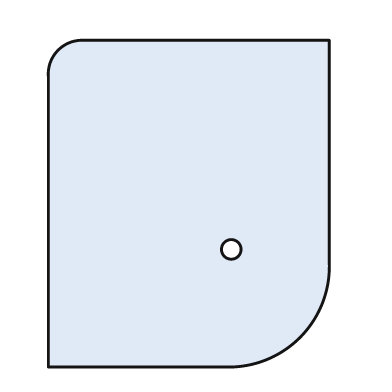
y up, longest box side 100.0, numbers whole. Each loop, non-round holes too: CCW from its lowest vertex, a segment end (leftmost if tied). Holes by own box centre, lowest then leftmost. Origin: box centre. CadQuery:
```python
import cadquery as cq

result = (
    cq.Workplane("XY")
    .moveTo(-43.0, -50.0)
    .lineTo(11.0, -50.0)
    .threePointArc((34.0, -41.0), (43.0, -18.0))
    .lineTo(43.0, 50.0)
    .lineTo(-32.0, 50.0)
    .threePointArc((-40.0, 47.0), (-43.0, 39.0))
    .close()
    .moveTo(13.0, -14.0)
    .circle(3.0)
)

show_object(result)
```